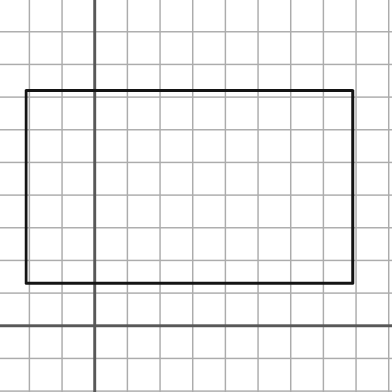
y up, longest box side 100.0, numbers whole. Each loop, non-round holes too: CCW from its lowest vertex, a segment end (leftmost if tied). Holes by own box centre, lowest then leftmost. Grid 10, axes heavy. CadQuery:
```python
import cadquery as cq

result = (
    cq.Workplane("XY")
    .moveTo(-21.0, 13.0)
    .lineTo(79.0, 13.0)
    .lineTo(79.0, 72.0)
    .lineTo(-21.0, 72.0)
    .close()
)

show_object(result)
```